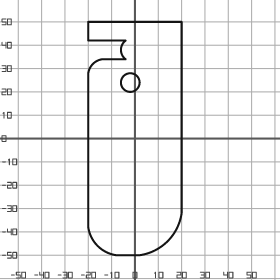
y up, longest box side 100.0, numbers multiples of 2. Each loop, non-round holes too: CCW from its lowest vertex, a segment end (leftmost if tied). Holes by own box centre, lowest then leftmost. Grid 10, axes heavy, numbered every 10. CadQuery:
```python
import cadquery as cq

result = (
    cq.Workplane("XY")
    .moveTo(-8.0, -50.0)
    .lineTo(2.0, -50.0)
    .threePointArc((14.0, -44.0), (20.0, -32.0))
    .lineTo(20.0, 50.0)
    .lineTo(-20.0, 50.0)
    .lineTo(-20.0, 42.0)
    .lineTo(-4.0, 42.0)
    .threePointArc((-6.0, 38.0), (-4.0, 34.0))
    .lineTo(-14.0, 34.0)
    .threePointArc((-18.0, 32.0), (-20.0, 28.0))
    .lineTo(-20.0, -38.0)
    .threePointArc((-16.0, -46.0), (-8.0, -50.0))
    .close()
    .moveTo(-2.0, 24.0)
    .circle(4.0)
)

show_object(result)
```